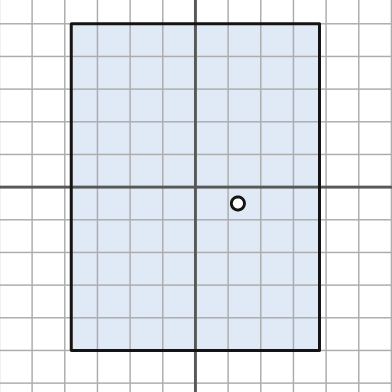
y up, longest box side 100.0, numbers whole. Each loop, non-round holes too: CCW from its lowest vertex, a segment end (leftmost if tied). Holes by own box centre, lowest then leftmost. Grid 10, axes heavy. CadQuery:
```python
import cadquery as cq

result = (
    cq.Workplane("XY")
    .moveTo(-38.0, -50.0)
    .lineTo(38.0, -50.0)
    .lineTo(38.0, 50.0)
    .lineTo(-38.0, 50.0)
    .close()
    .moveTo(13.0, -5.0)
    .circle(2.0)
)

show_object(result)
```